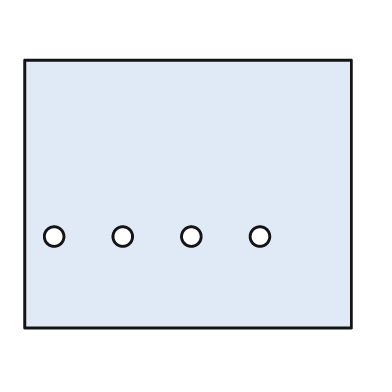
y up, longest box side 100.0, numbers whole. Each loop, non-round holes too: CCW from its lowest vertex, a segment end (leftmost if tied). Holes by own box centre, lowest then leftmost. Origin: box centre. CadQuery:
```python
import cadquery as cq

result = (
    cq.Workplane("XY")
    .moveTo(-50.0, -41.0)
    .lineTo(50.0, -41.0)
    .lineTo(50.0, 41.0)
    .lineTo(-50.0, 41.0)
    .close()
    .moveTo(-41.0, -13.0)
    .circle(3.0)
    .moveTo(-20.0, -13.0)
    .circle(3.0)
    .moveTo(1.0, -13.0)
    .circle(3.0)
    .moveTo(22.0, -13.0)
    .circle(3.0)
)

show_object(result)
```